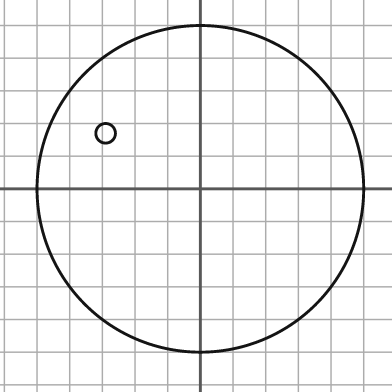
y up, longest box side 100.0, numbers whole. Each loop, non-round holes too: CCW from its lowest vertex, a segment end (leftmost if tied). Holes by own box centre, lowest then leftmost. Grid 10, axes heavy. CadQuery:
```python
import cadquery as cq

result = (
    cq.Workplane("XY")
    .moveTo(0.0, 0.0)
    .circle(50.0)
    .moveTo(-29.0, 17.0)
    .circle(3.0)
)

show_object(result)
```